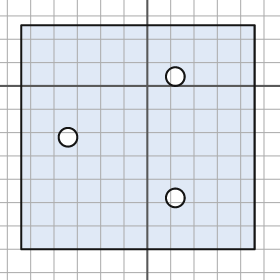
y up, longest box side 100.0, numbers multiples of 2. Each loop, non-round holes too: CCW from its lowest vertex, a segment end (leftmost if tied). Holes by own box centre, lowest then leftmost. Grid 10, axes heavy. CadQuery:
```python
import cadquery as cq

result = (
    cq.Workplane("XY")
    .moveTo(-54.0, -70.0)
    .lineTo(46.0, -70.0)
    .lineTo(46.0, 26.0)
    .lineTo(-54.0, 26.0)
    .close()
    .moveTo(12.0, -48.0)
    .circle(4.0)
    .moveTo(-34.0, -22.0)
    .circle(4.0)
    .moveTo(12.0, 4.0)
    .circle(4.0)
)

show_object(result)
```